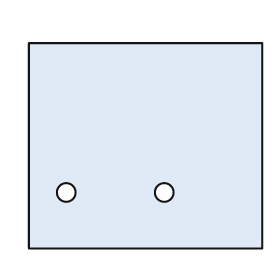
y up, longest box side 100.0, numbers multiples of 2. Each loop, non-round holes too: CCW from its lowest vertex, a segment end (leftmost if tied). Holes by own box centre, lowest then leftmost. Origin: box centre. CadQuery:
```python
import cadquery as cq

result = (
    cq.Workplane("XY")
    .moveTo(-50.0, -44.0)
    .lineTo(50.0, -44.0)
    .lineTo(50.0, 44.0)
    .lineTo(-50.0, 44.0)
    .close()
    .moveTo(-34.0, -20.0)
    .circle(4.0)
    .moveTo(8.0, -20.0)
    .circle(4.0)
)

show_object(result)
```